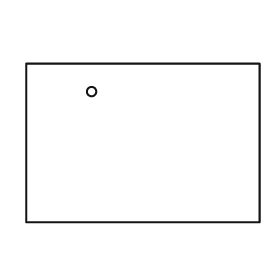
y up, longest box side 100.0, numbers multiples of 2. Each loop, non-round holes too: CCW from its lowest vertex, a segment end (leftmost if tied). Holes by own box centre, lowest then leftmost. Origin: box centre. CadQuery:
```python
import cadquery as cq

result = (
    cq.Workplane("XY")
    .moveTo(-50.0, -34.0)
    .lineTo(50.0, -34.0)
    .lineTo(50.0, 34.0)
    .lineTo(-50.0, 34.0)
    .close()
    .moveTo(-22.0, 22.0)
    .circle(2.0)
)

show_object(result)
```